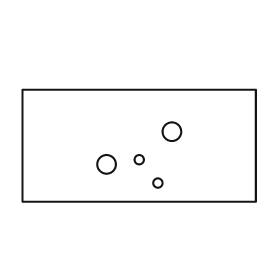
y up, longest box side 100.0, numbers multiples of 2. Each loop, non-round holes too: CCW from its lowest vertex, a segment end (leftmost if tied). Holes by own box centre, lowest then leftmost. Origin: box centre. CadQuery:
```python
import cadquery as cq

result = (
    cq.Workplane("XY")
    .moveTo(-50.0, -24.0)
    .lineTo(50.0, -24.0)
    .lineTo(50.0, 24.0)
    .lineTo(-50.0, 24.0)
    .close()
    .moveTo(8.0, -16.0)
    .circle(2.0)
    .moveTo(-14.0, -8.0)
    .circle(4.0)
    .moveTo(0.0, -6.0)
    .circle(2.0)
    .moveTo(14.0, 6.0)
    .circle(4.0)
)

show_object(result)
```